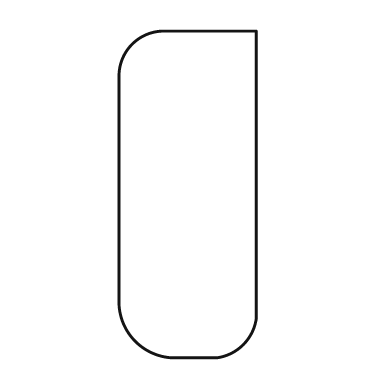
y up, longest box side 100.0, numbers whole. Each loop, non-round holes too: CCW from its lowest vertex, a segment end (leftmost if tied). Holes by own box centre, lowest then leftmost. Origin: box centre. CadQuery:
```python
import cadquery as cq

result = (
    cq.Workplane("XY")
    .moveTo(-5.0, -50.0)
    .lineTo(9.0, -50.0)
    .threePointArc((17.0, -46.0), (21.0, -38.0))
    .lineTo(21.0, 50.0)
    .lineTo(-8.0, 50.0)
    .threePointArc((-17.0, 46.0), (-21.0, 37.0))
    .lineTo(-21.0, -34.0)
    .threePointArc((-16.0, -45.0), (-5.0, -50.0))
    .close()
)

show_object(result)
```